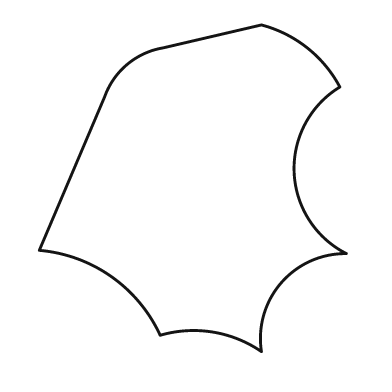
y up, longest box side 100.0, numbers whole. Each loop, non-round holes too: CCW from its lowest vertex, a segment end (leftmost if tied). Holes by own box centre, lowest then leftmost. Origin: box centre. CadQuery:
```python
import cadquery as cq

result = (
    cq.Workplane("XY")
    .moveTo(21.0, -50.0)
    .threePointArc((27.0, -29.0), (47.0, -20.0))
    .threePointArc((31.0, 5.0), (45.0, 31.0))
    .threePointArc((35.0, 43.0), (21.0, 50.0))
    .lineTo(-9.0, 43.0)
    .threePointArc((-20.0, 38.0), (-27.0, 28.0))
    .lineTo(-47.0, -19.0)
    .threePointArc((-25.0, -27.0), (-10.0, -45.0))
    .threePointArc((6.0, -44.0), (21.0, -50.0))
    .close()
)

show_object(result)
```